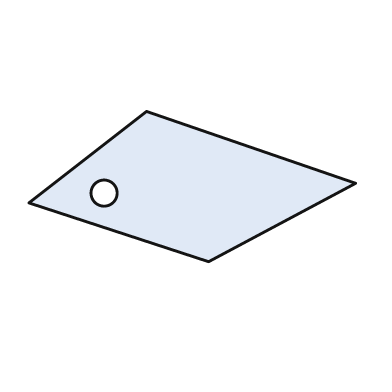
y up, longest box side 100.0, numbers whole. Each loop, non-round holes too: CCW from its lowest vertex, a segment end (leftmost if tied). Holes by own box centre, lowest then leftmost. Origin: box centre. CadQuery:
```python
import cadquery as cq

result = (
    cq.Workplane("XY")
    .moveTo(5.0, -23.0)
    .lineTo(50.0, 1.0)
    .lineTo(-14.0, 23.0)
    .lineTo(-50.0, -5.0)
    .close()
    .moveTo(-27.0, -2.0)
    .circle(4.0)
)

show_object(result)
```